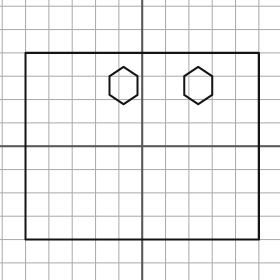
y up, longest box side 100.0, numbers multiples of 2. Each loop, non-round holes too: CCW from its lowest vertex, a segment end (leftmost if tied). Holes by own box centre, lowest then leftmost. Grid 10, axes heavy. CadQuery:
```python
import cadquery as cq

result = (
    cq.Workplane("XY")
    .moveTo(-50.0, -40.0)
    .lineTo(50.0, -40.0)
    .lineTo(50.0, 40.0)
    .lineTo(-50.0, 40.0)
    .close()
    .moveTo(-8.0, 18.0)
    .lineTo(-2.0, 22.0)
    .lineTo(-2.0, 30.0)
    .lineTo(-8.0, 34.0)
    .lineTo(-14.0, 30.0)
    .lineTo(-14.0, 22.0)
    .close()
    .moveTo(24.0, 18.0)
    .lineTo(30.0, 22.0)
    .lineTo(30.0, 30.0)
    .lineTo(24.0, 34.0)
    .lineTo(18.0, 30.0)
    .lineTo(18.0, 22.0)
    .close()
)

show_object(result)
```